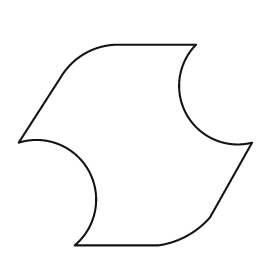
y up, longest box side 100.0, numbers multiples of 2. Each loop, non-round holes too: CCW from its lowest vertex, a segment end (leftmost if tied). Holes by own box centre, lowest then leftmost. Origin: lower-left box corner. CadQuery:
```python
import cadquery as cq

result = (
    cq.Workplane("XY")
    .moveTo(24.0, 0.0)
    .lineTo(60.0, 0.0)
    .threePointArc((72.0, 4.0), (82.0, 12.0))
    .lineTo(100.0, 44.0)
    .threePointArc((72.0, 56.0), (76.0, 86.0))
    .lineTo(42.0, 86.0)
    .threePointArc((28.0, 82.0), (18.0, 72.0))
    .lineTo(0.0, 44.0)
    .threePointArc((30.0, 32.0), (24.0, 0.0))
    .close()
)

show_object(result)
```